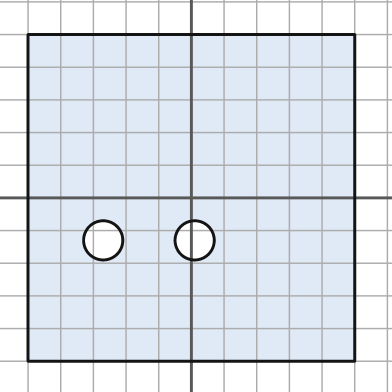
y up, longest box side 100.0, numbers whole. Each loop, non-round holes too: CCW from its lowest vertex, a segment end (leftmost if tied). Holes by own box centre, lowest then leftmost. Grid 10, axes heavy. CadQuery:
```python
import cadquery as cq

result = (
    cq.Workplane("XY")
    .moveTo(-50.0, -50.0)
    .lineTo(50.0, -50.0)
    .lineTo(50.0, 50.0)
    .lineTo(-50.0, 50.0)
    .close()
    .moveTo(-27.0, -13.0)
    .circle(6.0)
    .moveTo(1.0, -13.0)
    .circle(6.0)
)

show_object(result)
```